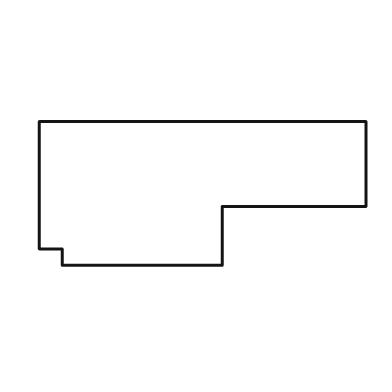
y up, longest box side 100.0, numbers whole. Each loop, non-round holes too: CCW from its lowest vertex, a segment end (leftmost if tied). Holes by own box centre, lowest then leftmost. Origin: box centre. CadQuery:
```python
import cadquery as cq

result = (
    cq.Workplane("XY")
    .moveTo(-43.0, -22.0)
    .lineTo(6.0, -22.0)
    .lineTo(6.0, -4.0)
    .lineTo(50.0, -4.0)
    .lineTo(50.0, 22.0)
    .lineTo(-50.0, 22.0)
    .lineTo(-50.0, -17.0)
    .lineTo(-43.0, -17.0)
    .close()
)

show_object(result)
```